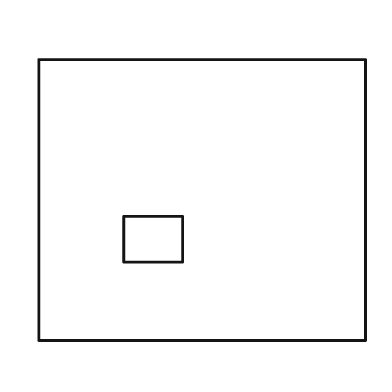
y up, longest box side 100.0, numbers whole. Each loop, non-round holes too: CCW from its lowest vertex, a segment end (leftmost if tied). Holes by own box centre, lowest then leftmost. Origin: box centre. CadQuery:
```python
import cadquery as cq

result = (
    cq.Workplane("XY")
    .moveTo(-50.0, -43.0)
    .lineTo(50.0, -43.0)
    .lineTo(50.0, 43.0)
    .lineTo(-50.0, 43.0)
    .close()
    .moveTo(-24.0, -19.0)
    .lineTo(-6.0, -19.0)
    .lineTo(-6.0, -5.0)
    .lineTo(-24.0, -5.0)
    .close()
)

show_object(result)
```